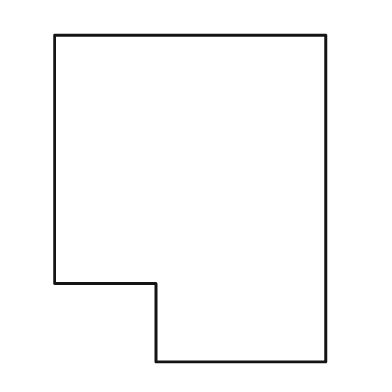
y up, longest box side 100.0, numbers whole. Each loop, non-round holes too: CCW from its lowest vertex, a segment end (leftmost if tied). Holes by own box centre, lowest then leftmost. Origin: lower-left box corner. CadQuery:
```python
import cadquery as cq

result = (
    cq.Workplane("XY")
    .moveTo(31.0, 0.0)
    .lineTo(83.0, 0.0)
    .lineTo(83.0, 100.0)
    .lineTo(0.0, 100.0)
    .lineTo(0.0, 24.0)
    .lineTo(31.0, 24.0)
    .close()
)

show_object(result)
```